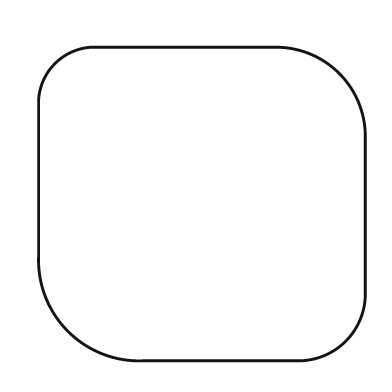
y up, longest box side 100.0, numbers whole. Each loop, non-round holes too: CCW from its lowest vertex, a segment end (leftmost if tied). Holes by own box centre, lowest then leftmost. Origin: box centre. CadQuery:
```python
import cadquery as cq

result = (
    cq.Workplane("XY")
    .moveTo(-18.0, -48.0)
    .lineTo(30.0, -48.0)
    .threePointArc((44.0, -42.0), (50.0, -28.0))
    .lineTo(50.0, 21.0)
    .threePointArc((42.0, 40.0), (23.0, 48.0))
    .lineTo(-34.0, 48.0)
    .threePointArc((-45.0, 43.0), (-50.0, 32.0))
    .lineTo(-50.0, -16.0)
    .threePointArc((-41.0, -39.0), (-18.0, -48.0))
    .close()
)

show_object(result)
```